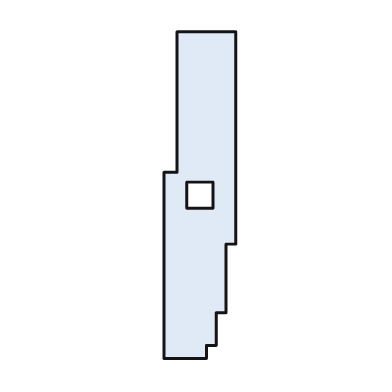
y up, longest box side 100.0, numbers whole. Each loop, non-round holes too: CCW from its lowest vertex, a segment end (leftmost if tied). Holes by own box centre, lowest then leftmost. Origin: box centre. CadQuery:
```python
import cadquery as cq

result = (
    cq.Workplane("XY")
    .moveTo(-11.0, -50.0)
    .lineTo(2.0, -50.0)
    .lineTo(2.0, -46.0)
    .lineTo(5.0, -46.0)
    .lineTo(5.0, -36.0)
    .lineTo(8.0, -36.0)
    .lineTo(8.0, -15.0)
    .lineTo(11.0, -15.0)
    .lineTo(11.0, 50.0)
    .lineTo(-7.0, 50.0)
    .lineTo(-7.0, 7.0)
    .lineTo(-11.0, 7.0)
    .close()
    .moveTo(-4.0, -4.0)
    .lineTo(4.0, -4.0)
    .lineTo(4.0, 4.0)
    .lineTo(-4.0, 4.0)
    .close()
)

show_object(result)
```